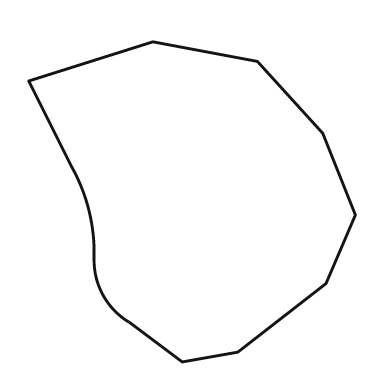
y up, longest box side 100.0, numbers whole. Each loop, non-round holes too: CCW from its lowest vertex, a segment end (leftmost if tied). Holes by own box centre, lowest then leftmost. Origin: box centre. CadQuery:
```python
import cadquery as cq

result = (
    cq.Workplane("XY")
    .moveTo(-3.0, -49.0)
    .lineTo(14.0, -46.0)
    .lineTo(41.0, -25.0)
    .lineTo(50.0, -4.0)
    .lineTo(40.0, 21.0)
    .lineTo(20.0, 43.0)
    .lineTo(-12.0, 49.0)
    .lineTo(-50.0, 37.0)
    .lineTo(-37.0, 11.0)
    .threePointArc((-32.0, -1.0), (-30.0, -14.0))
    .lineTo(-30.0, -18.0)
    .threePointArc((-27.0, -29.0), (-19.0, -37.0))
    .close()
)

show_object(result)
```